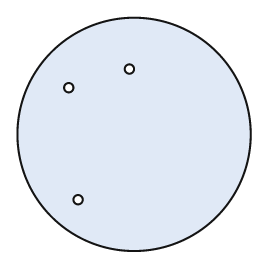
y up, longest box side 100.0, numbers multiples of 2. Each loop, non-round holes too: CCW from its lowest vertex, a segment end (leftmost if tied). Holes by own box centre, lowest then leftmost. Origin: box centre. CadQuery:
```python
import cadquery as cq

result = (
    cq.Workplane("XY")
    .moveTo(0.0, 0.0)
    .circle(50.0)
    .moveTo(-24.0, -28.0)
    .circle(2.0)
    .moveTo(-28.0, 20.0)
    .circle(2.0)
    .moveTo(-2.0, 28.0)
    .circle(2.0)
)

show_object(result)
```